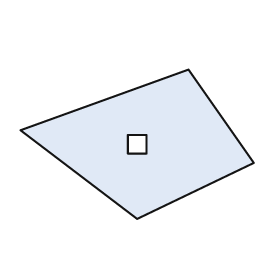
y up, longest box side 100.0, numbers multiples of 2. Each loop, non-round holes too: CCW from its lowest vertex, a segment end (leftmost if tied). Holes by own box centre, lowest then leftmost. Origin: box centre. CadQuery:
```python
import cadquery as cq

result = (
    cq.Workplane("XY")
    .moveTo(0.0, -32.0)
    .lineTo(50.0, -8.0)
    .lineTo(22.0, 32.0)
    .lineTo(-50.0, 6.0)
    .close()
    .moveTo(-4.0, -4.0)
    .lineTo(4.0, -4.0)
    .lineTo(4.0, 4.0)
    .lineTo(-4.0, 4.0)
    .close()
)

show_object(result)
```